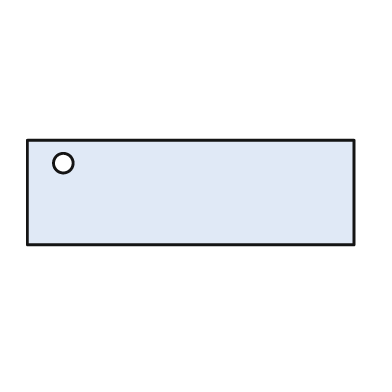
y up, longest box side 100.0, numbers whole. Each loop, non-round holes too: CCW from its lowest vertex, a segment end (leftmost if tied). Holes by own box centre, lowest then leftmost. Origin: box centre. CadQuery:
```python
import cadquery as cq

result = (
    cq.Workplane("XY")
    .moveTo(-50.0, -16.0)
    .lineTo(50.0, -16.0)
    .lineTo(50.0, 16.0)
    .lineTo(-50.0, 16.0)
    .close()
    .moveTo(-39.0, 9.0)
    .circle(3.0)
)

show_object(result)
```